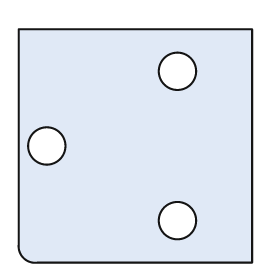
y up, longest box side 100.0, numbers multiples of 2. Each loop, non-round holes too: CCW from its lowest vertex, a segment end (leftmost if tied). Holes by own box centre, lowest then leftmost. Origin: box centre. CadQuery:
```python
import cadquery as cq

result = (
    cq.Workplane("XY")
    .moveTo(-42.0, -50.0)
    .lineTo(50.0, -50.0)
    .lineTo(50.0, 50.0)
    .lineTo(-50.0, 50.0)
    .lineTo(-50.0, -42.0)
    .threePointArc((-48.0, -48.0), (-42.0, -50.0))
    .close()
    .moveTo(18.0, -32.0)
    .circle(8.0)
    .moveTo(-38.0, 0.0)
    .circle(8.0)
    .moveTo(18.0, 32.0)
    .circle(8.0)
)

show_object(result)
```